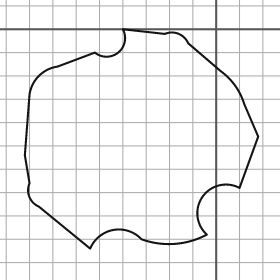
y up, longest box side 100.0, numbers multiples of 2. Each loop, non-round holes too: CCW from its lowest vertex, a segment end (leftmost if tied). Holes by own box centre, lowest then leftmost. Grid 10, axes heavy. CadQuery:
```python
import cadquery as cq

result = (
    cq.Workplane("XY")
    .moveTo(-54.0, -94.0)
    .threePointArc((-44.0, -86.0), (-32.0, -90.0))
    .threePointArc((-18.0, -92.0), (-4.0, -88.0))
    .threePointArc((-6.0, -72.0), (10.0, -68.0))
    .lineTo(18.0, -46.0)
    .lineTo(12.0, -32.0)
    .threePointArc((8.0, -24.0), (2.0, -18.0))
    .lineTo(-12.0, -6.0)
    .threePointArc((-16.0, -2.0), (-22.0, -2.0))
    .lineTo(-40.0, 0.0)
    .threePointArc((-42.0, -10.0), (-52.0, -10.0))
    .lineTo(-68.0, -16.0)
    .threePointArc((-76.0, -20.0), (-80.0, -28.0))
    .lineTo(-82.0, -54.0)
    .lineTo(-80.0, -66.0)
    .threePointArc((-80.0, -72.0), (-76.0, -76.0))
    .close()
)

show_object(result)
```